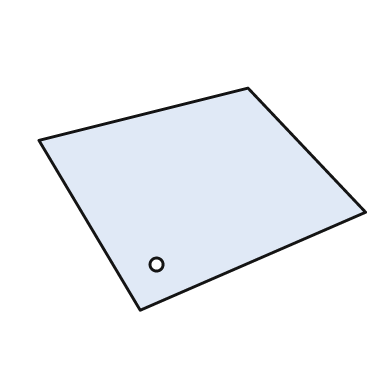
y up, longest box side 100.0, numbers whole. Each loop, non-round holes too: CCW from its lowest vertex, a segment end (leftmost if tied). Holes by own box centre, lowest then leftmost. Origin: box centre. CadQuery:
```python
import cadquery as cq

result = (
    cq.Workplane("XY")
    .moveTo(-19.0, -34.0)
    .lineTo(50.0, -4.0)
    .lineTo(14.0, 34.0)
    .lineTo(-50.0, 18.0)
    .close()
    .moveTo(-14.0, -20.0)
    .circle(2.0)
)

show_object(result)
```